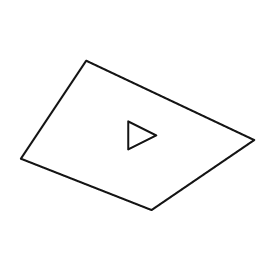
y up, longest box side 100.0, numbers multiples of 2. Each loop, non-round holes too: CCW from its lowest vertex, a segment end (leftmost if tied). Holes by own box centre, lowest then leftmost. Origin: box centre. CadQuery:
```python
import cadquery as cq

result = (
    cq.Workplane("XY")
    .moveTo(6.0, -32.0)
    .lineTo(50.0, -2.0)
    .lineTo(-22.0, 32.0)
    .lineTo(-50.0, -10.0)
    .close()
    .moveTo(-4.0, -6.0)
    .lineTo(8.0, 0.0)
    .lineTo(-4.0, 6.0)
    .close()
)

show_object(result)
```